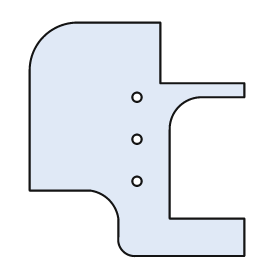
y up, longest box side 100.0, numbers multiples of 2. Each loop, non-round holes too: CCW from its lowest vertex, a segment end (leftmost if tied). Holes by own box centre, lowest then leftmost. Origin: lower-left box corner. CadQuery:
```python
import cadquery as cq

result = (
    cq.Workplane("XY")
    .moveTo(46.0, 0.0)
    .lineTo(92.0, 0.0)
    .lineTo(92.0, 16.0)
    .lineTo(60.0, 16.0)
    .lineTo(60.0, 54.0)
    .threePointArc((64.0, 64.0), (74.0, 68.0))
    .lineTo(92.0, 68.0)
    .lineTo(92.0, 74.0)
    .lineTo(56.0, 74.0)
    .lineTo(56.0, 100.0)
    .lineTo(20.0, 100.0)
    .threePointArc((6.0, 94.0), (0.0, 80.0))
    .lineTo(0.0, 28.0)
    .lineTo(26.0, 28.0)
    .threePointArc((34.0, 24.0), (38.0, 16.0))
    .lineTo(38.0, 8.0)
    .threePointArc((40.0, 2.0), (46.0, 0.0))
    .close()
    .moveTo(46.0, 32.0)
    .circle(2.0)
    .moveTo(46.0, 50.0)
    .circle(2.0)
    .moveTo(46.0, 68.0)
    .circle(2.0)
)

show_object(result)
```